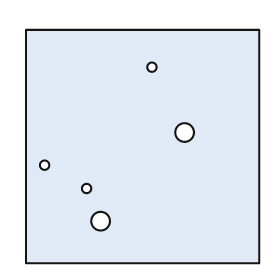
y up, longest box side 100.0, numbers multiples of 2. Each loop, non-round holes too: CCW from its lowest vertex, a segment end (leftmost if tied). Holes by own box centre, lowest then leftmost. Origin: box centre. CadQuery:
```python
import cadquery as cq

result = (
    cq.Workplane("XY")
    .moveTo(-50.0, -50.0)
    .lineTo(50.0, -50.0)
    .lineTo(50.0, 50.0)
    .lineTo(-50.0, 50.0)
    .close()
    .moveTo(-18.0, -32.0)
    .circle(4.0)
    .moveTo(-24.0, -18.0)
    .circle(2.0)
    .moveTo(-42.0, -8.0)
    .circle(2.0)
    .moveTo(18.0, 6.0)
    .circle(4.0)
    .moveTo(4.0, 34.0)
    .circle(2.0)
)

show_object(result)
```